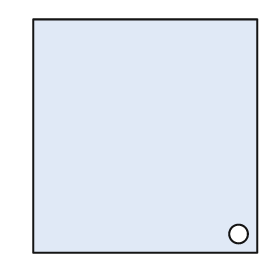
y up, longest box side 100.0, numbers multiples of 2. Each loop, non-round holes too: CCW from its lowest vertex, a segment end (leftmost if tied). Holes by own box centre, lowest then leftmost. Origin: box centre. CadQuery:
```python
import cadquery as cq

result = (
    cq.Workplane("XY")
    .moveTo(-48.0, -50.0)
    .lineTo(48.0, -50.0)
    .lineTo(48.0, 50.0)
    .lineTo(-48.0, 50.0)
    .close()
    .moveTo(40.0, -42.0)
    .circle(4.0)
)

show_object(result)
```